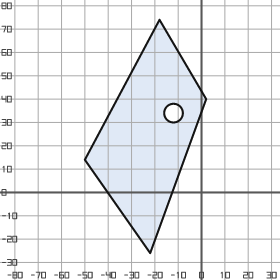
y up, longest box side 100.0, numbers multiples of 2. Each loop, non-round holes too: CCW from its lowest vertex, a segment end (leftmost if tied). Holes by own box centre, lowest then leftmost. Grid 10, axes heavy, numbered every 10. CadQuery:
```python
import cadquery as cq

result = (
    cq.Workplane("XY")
    .moveTo(-22.0, -26.0)
    .lineTo(2.0, 40.0)
    .lineTo(-18.0, 74.0)
    .lineTo(-50.0, 14.0)
    .close()
    .moveTo(-12.0, 34.0)
    .circle(4.0)
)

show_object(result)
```